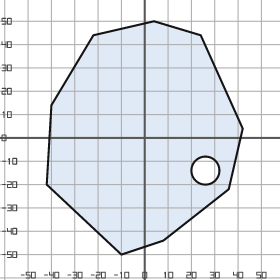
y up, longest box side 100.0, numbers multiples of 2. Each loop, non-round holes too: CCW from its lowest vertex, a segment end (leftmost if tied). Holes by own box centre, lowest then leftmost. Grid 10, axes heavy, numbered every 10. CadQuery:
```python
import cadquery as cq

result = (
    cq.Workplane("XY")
    .moveTo(-10.0, -50.0)
    .lineTo(8.0, -44.0)
    .lineTo(36.0, -22.0)
    .lineTo(42.0, 4.0)
    .lineTo(24.0, 44.0)
    .lineTo(4.0, 50.0)
    .lineTo(-22.0, 44.0)
    .lineTo(-40.0, 14.0)
    .lineTo(-42.0, -20.0)
    .close()
    .moveTo(26.0, -14.0)
    .circle(6.0)
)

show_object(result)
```